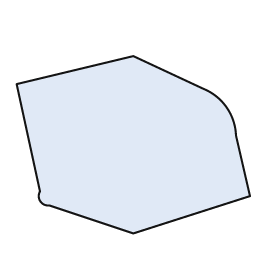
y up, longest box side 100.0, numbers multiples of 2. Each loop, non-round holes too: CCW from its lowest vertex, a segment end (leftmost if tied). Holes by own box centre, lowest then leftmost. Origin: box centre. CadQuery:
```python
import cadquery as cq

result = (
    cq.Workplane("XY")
    .moveTo(0.0, -38.0)
    .lineTo(50.0, -22.0)
    .lineTo(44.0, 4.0)
    .threePointArc((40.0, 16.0), (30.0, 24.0))
    .lineTo(0.0, 38.0)
    .lineTo(-50.0, 26.0)
    .lineTo(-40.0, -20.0)
    .threePointArc((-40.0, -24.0), (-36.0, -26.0))
    .close()
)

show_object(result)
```